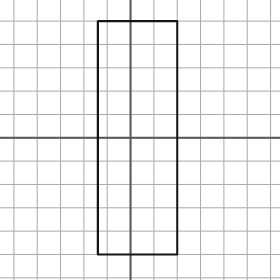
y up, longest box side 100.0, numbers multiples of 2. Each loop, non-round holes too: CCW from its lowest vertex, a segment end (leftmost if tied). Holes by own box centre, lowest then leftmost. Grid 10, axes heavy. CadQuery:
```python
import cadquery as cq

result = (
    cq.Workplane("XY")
    .moveTo(-14.0, -50.0)
    .lineTo(20.0, -50.0)
    .lineTo(20.0, 50.0)
    .lineTo(-14.0, 50.0)
    .close()
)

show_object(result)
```